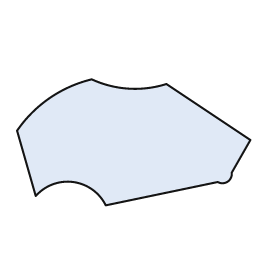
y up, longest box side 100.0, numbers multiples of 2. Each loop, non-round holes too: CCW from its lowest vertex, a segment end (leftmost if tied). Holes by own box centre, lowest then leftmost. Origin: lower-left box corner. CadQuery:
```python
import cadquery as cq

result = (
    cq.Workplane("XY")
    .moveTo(38.0, 0.0)
    .lineTo(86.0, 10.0)
    .threePointArc((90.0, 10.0), (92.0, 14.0))
    .lineTo(100.0, 28.0)
    .lineTo(64.0, 52.0)
    .threePointArc((48.0, 50.0), (32.0, 54.0))
    .threePointArc((14.0, 46.0), (0.0, 32.0))
    .lineTo(8.0, 4.0)
    .threePointArc((24.0, 10.0), (38.0, 0.0))
    .close()
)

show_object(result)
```